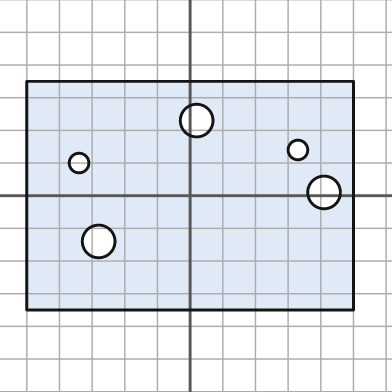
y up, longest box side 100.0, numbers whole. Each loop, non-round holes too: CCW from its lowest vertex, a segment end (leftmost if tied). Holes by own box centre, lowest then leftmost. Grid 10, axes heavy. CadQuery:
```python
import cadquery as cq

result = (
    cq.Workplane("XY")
    .moveTo(-50.0, -35.0)
    .lineTo(50.0, -35.0)
    .lineTo(50.0, 35.0)
    .lineTo(-50.0, 35.0)
    .close()
    .moveTo(-28.0, -14.0)
    .circle(5.0)
    .moveTo(41.0, 1.0)
    .circle(5.0)
    .moveTo(-34.0, 10.0)
    .circle(3.0)
    .moveTo(33.0, 14.0)
    .circle(3.0)
    .moveTo(2.0, 23.0)
    .circle(5.0)
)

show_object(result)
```